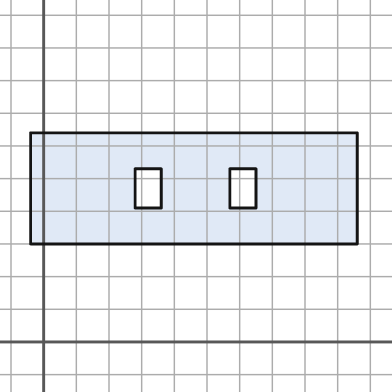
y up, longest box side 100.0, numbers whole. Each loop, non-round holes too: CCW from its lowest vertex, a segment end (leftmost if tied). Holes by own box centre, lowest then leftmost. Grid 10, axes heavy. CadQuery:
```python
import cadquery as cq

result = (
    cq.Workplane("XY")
    .moveTo(-4.0, 30.0)
    .lineTo(96.0, 30.0)
    .lineTo(96.0, 64.0)
    .lineTo(-4.0, 64.0)
    .close()
    .moveTo(28.0, 41.0)
    .lineTo(36.0, 41.0)
    .lineTo(36.0, 53.0)
    .lineTo(28.0, 53.0)
    .close()
    .moveTo(57.0, 41.0)
    .lineTo(65.0, 41.0)
    .lineTo(65.0, 53.0)
    .lineTo(57.0, 53.0)
    .close()
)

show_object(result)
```